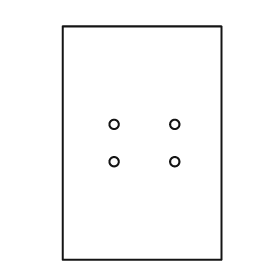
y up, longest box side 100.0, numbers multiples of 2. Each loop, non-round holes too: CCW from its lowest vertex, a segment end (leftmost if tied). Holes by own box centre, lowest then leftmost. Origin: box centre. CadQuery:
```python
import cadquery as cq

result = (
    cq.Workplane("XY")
    .moveTo(-34.0, -50.0)
    .lineTo(34.0, -50.0)
    .lineTo(34.0, 50.0)
    .lineTo(-34.0, 50.0)
    .close()
    .moveTo(-12.0, -8.0)
    .circle(2.0)
    .moveTo(14.0, -8.0)
    .circle(2.0)
    .moveTo(-12.0, 8.0)
    .circle(2.0)
    .moveTo(14.0, 8.0)
    .circle(2.0)
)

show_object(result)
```